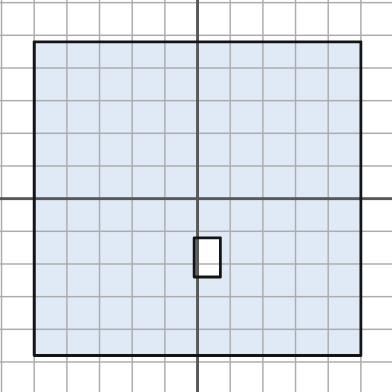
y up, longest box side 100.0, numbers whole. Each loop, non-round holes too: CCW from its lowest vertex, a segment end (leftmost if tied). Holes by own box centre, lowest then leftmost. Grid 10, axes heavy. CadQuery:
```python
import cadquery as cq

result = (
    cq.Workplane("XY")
    .moveTo(-50.0, -48.0)
    .lineTo(50.0, -48.0)
    .lineTo(50.0, 48.0)
    .lineTo(-50.0, 48.0)
    .close()
    .moveTo(-1.0, -24.0)
    .lineTo(7.0, -24.0)
    .lineTo(7.0, -12.0)
    .lineTo(-1.0, -12.0)
    .close()
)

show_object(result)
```